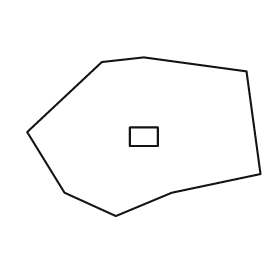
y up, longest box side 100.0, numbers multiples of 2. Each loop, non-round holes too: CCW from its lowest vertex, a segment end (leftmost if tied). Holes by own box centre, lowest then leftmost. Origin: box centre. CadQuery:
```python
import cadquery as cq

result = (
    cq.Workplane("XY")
    .moveTo(-12.0, -34.0)
    .lineTo(12.0, -24.0)
    .lineTo(50.0, -16.0)
    .lineTo(44.0, 28.0)
    .lineTo(0.0, 34.0)
    .lineTo(-18.0, 32.0)
    .lineTo(-50.0, 2.0)
    .lineTo(-34.0, -24.0)
    .close()
    .moveTo(-6.0, -4.0)
    .lineTo(6.0, -4.0)
    .lineTo(6.0, 4.0)
    .lineTo(-6.0, 4.0)
    .close()
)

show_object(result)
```